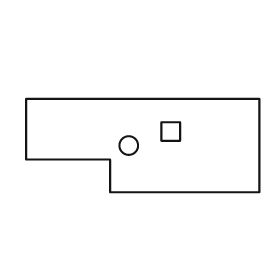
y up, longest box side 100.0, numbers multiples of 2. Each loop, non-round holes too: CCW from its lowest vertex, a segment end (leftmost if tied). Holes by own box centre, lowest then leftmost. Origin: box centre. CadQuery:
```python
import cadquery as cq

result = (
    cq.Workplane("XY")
    .moveTo(-14.0, -20.0)
    .lineTo(50.0, -20.0)
    .lineTo(50.0, 20.0)
    .lineTo(-50.0, 20.0)
    .lineTo(-50.0, -6.0)
    .lineTo(-14.0, -6.0)
    .close()
    .moveTo(-6.0, 0.0)
    .circle(4.0)
    .moveTo(8.0, 2.0)
    .lineTo(16.0, 2.0)
    .lineTo(16.0, 10.0)
    .lineTo(8.0, 10.0)
    .close()
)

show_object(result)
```